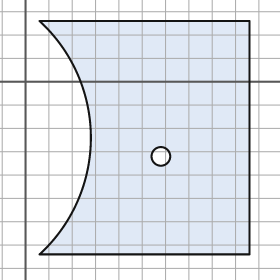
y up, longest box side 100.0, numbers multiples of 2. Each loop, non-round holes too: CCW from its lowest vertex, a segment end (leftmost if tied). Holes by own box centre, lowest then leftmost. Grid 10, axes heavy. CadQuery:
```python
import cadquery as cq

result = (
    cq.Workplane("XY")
    .moveTo(6.0, -74.0)
    .lineTo(96.0, -74.0)
    .lineTo(96.0, 26.0)
    .lineTo(6.0, 26.0)
    .threePointArc((28.0, -24.0), (6.0, -74.0))
    .close()
    .moveTo(58.0, -32.0)
    .circle(4.0)
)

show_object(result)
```